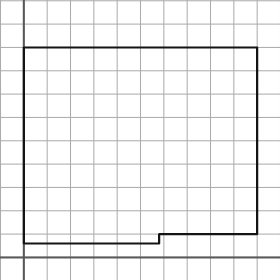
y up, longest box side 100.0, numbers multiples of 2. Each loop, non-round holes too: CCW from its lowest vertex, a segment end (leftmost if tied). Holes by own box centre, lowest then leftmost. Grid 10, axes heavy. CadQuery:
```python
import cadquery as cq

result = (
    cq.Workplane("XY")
    .moveTo(0.0, 6.0)
    .lineTo(58.0, 6.0)
    .lineTo(58.0, 10.0)
    .lineTo(100.0, 10.0)
    .lineTo(100.0, 90.0)
    .lineTo(0.0, 90.0)
    .close()
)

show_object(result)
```